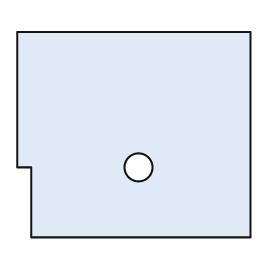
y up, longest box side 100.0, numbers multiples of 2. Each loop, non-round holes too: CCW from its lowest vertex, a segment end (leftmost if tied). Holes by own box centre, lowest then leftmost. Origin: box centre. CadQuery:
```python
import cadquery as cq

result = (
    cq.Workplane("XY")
    .moveTo(-44.0, -44.0)
    .lineTo(50.0, -44.0)
    .lineTo(50.0, 44.0)
    .lineTo(-50.0, 44.0)
    .lineTo(-50.0, -14.0)
    .lineTo(-44.0, -14.0)
    .close()
    .moveTo(2.0, -14.0)
    .circle(6.0)
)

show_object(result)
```